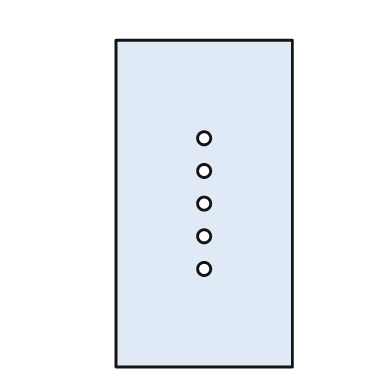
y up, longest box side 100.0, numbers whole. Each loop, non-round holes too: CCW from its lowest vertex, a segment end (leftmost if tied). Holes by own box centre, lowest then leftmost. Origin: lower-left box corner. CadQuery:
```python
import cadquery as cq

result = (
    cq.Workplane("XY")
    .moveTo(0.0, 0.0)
    .lineTo(54.0, 0.0)
    .lineTo(54.0, 100.0)
    .lineTo(0.0, 100.0)
    .close()
    .moveTo(27.0, 30.0)
    .circle(2.0)
    .moveTo(27.0, 40.0)
    .circle(2.0)
    .moveTo(27.0, 50.0)
    .circle(2.0)
    .moveTo(27.0, 60.0)
    .circle(2.0)
    .moveTo(27.0, 70.0)
    .circle(2.0)
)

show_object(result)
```